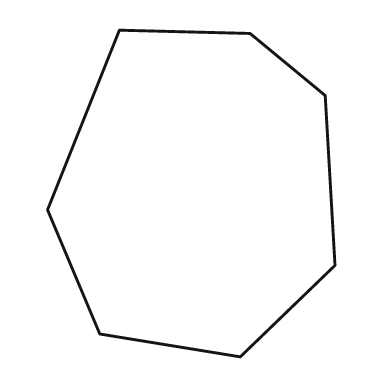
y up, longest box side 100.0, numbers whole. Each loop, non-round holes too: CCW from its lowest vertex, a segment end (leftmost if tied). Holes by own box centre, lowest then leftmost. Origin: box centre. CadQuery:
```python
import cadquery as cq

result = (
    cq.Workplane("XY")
    .moveTo(15.0, -50.0)
    .lineTo(44.0, -22.0)
    .lineTo(41.0, 30.0)
    .lineTo(18.0, 49.0)
    .lineTo(-22.0, 50.0)
    .lineTo(-44.0, -5.0)
    .lineTo(-28.0, -43.0)
    .close()
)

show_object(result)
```